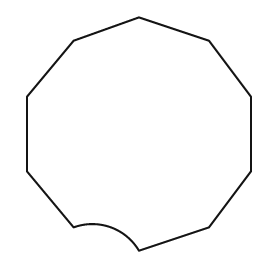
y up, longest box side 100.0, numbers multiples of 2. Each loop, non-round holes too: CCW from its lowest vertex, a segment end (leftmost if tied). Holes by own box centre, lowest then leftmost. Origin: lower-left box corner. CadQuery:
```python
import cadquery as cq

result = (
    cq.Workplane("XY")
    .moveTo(48.0, 0.0)
    .lineTo(78.0, 10.0)
    .lineTo(96.0, 34.0)
    .lineTo(96.0, 66.0)
    .lineTo(78.0, 90.0)
    .lineTo(48.0, 100.0)
    .lineTo(20.0, 90.0)
    .lineTo(0.0, 66.0)
    .lineTo(0.0, 34.0)
    .lineTo(20.0, 10.0)
    .threePointArc((36.0, 10.0), (48.0, 0.0))
    .close()
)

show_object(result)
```